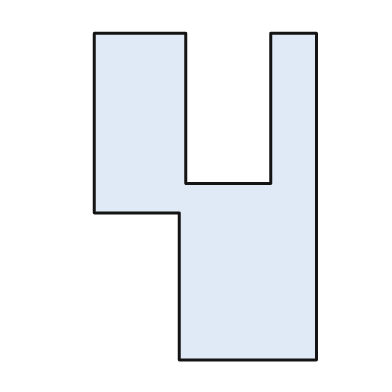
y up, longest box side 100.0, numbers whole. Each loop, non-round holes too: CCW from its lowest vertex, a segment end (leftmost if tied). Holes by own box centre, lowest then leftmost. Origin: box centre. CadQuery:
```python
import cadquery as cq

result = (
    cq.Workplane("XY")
    .moveTo(-8.0, -50.0)
    .lineTo(34.0, -50.0)
    .lineTo(34.0, 50.0)
    .lineTo(20.0, 50.0)
    .lineTo(20.0, 4.0)
    .lineTo(-6.0, 4.0)
    .lineTo(-6.0, 50.0)
    .lineTo(-34.0, 50.0)
    .lineTo(-34.0, -5.0)
    .lineTo(-8.0, -5.0)
    .close()
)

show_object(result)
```